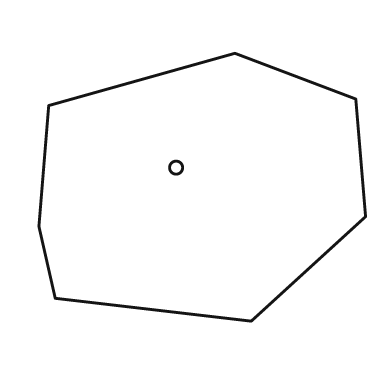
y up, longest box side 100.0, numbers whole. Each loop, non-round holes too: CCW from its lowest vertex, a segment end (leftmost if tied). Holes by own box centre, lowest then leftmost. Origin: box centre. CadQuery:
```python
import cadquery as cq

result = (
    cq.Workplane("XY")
    .moveTo(15.0, -41.0)
    .lineTo(50.0, -9.0)
    .lineTo(47.0, 27.0)
    .lineTo(10.0, 41.0)
    .lineTo(-47.0, 25.0)
    .lineTo(-50.0, -12.0)
    .lineTo(-45.0, -34.0)
    .close()
    .moveTo(-8.0, 6.0)
    .circle(2.0)
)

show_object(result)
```